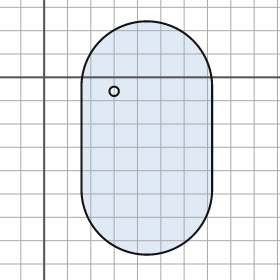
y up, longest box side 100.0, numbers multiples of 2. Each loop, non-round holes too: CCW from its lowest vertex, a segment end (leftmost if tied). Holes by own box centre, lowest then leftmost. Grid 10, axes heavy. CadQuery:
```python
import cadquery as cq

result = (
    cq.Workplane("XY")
    .moveTo(16.0, -48.0)
    .threePointArc((44.0, -76.0), (72.0, -48.0))
    .lineTo(72.0, -4.0)
    .threePointArc((44.0, 24.0), (16.0, -4.0))
    .close()
    .moveTo(30.0, -6.0)
    .circle(2.0)
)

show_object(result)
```